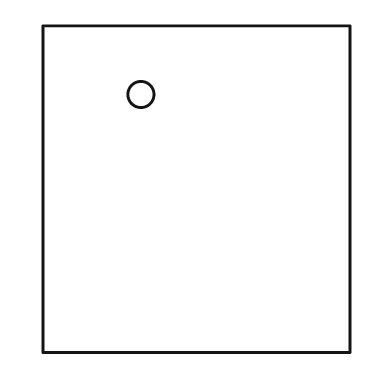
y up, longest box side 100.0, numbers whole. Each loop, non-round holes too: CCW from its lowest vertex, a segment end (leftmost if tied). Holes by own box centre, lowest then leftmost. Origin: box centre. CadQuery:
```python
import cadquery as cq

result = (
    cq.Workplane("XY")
    .moveTo(-47.0, -50.0)
    .lineTo(47.0, -50.0)
    .lineTo(47.0, 50.0)
    .lineTo(-47.0, 50.0)
    .close()
    .moveTo(-17.0, 29.0)
    .circle(4.0)
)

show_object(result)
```